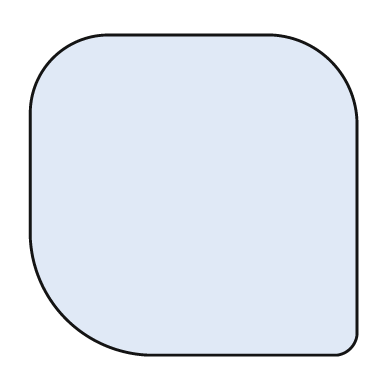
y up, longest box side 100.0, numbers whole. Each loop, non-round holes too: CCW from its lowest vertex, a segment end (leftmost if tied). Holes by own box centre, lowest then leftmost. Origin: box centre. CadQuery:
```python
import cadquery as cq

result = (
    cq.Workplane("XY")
    .moveTo(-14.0, -49.0)
    .lineTo(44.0, -49.0)
    .threePointArc((48.0, -47.0), (50.0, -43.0))
    .lineTo(50.0, 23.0)
    .threePointArc((42.0, 41.0), (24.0, 49.0))
    .lineTo(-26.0, 49.0)
    .threePointArc((-43.0, 42.0), (-50.0, 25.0))
    .lineTo(-50.0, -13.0)
    .threePointArc((-39.0, -38.0), (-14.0, -49.0))
    .close()
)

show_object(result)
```